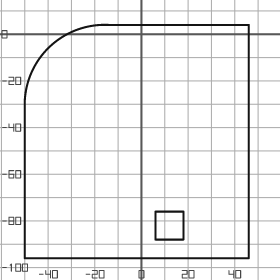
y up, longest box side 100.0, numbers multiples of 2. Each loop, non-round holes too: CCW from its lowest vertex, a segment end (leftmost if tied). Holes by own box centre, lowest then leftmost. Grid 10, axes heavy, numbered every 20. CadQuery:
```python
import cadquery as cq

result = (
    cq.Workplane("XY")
    .moveTo(-50.0, -96.0)
    .lineTo(46.0, -96.0)
    .lineTo(46.0, 4.0)
    .lineTo(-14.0, 4.0)
    .threePointArc((-40.0, -6.0), (-50.0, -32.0))
    .close()
    .moveTo(6.0, -88.0)
    .lineTo(18.0, -88.0)
    .lineTo(18.0, -76.0)
    .lineTo(6.0, -76.0)
    .close()
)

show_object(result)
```